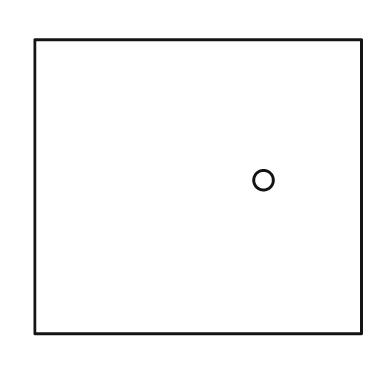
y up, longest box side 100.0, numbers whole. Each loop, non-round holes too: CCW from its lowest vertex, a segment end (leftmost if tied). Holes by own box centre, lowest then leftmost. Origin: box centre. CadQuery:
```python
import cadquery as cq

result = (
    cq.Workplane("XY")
    .moveTo(-50.0, -45.0)
    .lineTo(50.0, -45.0)
    .lineTo(50.0, 45.0)
    .lineTo(-50.0, 45.0)
    .close()
    .moveTo(20.0, 2.0)
    .circle(3.0)
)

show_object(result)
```